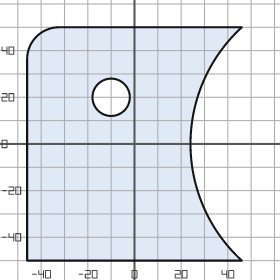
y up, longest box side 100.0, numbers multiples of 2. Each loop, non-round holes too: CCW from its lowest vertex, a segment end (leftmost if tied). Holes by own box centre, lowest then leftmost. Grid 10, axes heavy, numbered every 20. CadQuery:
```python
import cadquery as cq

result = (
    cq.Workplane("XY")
    .moveTo(-46.0, -50.0)
    .lineTo(46.0, -50.0)
    .threePointArc((24.0, 0.0), (46.0, 50.0))
    .lineTo(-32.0, 50.0)
    .threePointArc((-42.0, 46.0), (-46.0, 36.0))
    .close()
    .moveTo(-10.0, 20.0)
    .circle(8.0)
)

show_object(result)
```